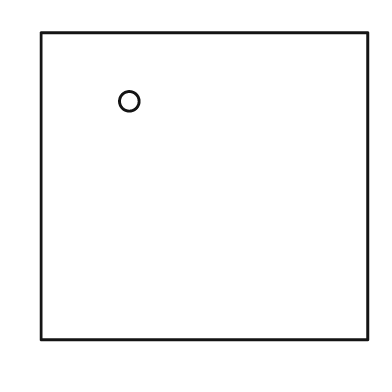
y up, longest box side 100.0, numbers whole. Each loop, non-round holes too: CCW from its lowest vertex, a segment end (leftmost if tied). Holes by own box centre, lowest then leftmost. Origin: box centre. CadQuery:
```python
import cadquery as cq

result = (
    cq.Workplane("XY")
    .moveTo(-50.0, -47.0)
    .lineTo(50.0, -47.0)
    .lineTo(50.0, 47.0)
    .lineTo(-50.0, 47.0)
    .close()
    .moveTo(-23.0, 26.0)
    .circle(3.0)
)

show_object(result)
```